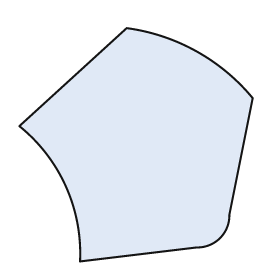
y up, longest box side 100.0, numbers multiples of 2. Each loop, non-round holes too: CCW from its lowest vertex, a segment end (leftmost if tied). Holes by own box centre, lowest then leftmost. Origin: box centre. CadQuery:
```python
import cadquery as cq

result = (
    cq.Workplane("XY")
    .moveTo(-24.0, -50.0)
    .lineTo(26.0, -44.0)
    .threePointArc((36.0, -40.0), (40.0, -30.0))
    .lineTo(50.0, 20.0)
    .threePointArc((26.0, 40.0), (-4.0, 50.0))
    .lineTo(-50.0, 8.0)
    .threePointArc((-30.0, -18.0), (-24.0, -50.0))
    .close()
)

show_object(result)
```